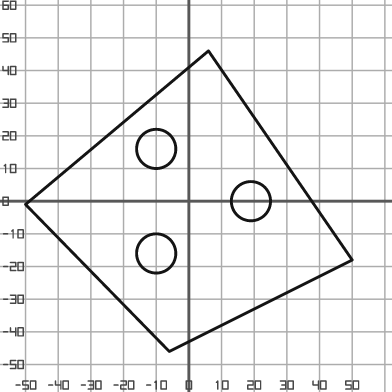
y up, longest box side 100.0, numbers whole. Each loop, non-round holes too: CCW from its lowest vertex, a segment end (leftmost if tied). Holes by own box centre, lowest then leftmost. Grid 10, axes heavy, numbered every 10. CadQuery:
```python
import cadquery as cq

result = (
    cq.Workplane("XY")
    .moveTo(-6.0, -46.0)
    .lineTo(50.0, -18.0)
    .lineTo(6.0, 46.0)
    .lineTo(-50.0, -1.0)
    .close()
    .moveTo(-10.0, -16.0)
    .circle(6.0)
    .moveTo(19.0, 0.0)
    .circle(6.0)
    .moveTo(-10.0, 16.0)
    .circle(6.0)
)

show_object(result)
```